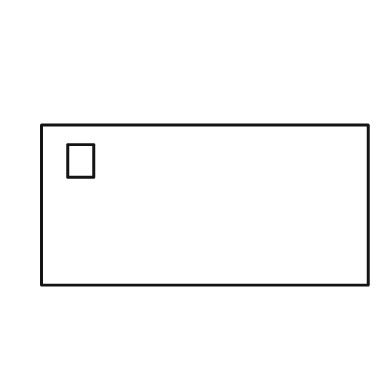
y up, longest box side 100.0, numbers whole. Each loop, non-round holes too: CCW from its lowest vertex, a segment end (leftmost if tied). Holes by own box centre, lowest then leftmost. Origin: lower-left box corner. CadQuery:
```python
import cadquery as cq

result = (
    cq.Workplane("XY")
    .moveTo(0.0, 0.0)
    .lineTo(100.0, 0.0)
    .lineTo(100.0, 49.0)
    .lineTo(0.0, 49.0)
    .close()
    .moveTo(8.0, 33.0)
    .lineTo(16.0, 33.0)
    .lineTo(16.0, 43.0)
    .lineTo(8.0, 43.0)
    .close()
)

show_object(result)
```